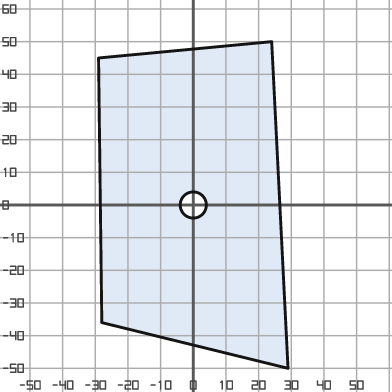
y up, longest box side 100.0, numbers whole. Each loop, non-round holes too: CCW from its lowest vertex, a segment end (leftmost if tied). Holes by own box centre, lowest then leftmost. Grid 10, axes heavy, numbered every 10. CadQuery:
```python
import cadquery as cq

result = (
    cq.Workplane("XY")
    .moveTo(29.0, -50.0)
    .lineTo(24.0, 50.0)
    .lineTo(-29.0, 45.0)
    .lineTo(-28.0, -36.0)
    .close()
    .moveTo(0.0, 0.0)
    .circle(4.0)
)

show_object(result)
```